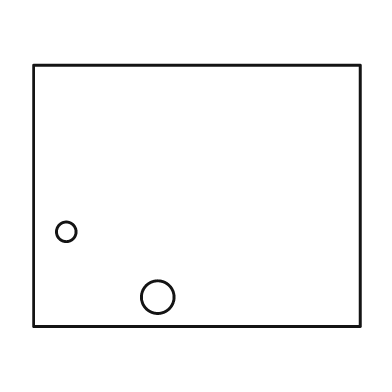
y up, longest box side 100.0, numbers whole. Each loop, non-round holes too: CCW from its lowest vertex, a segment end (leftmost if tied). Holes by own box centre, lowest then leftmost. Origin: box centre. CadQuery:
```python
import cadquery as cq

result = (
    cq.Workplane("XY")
    .moveTo(-50.0, -40.0)
    .lineTo(50.0, -40.0)
    .lineTo(50.0, 40.0)
    .lineTo(-50.0, 40.0)
    .close()
    .moveTo(-12.0, -31.0)
    .circle(5.0)
    .moveTo(-40.0, -11.0)
    .circle(3.0)
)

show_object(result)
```